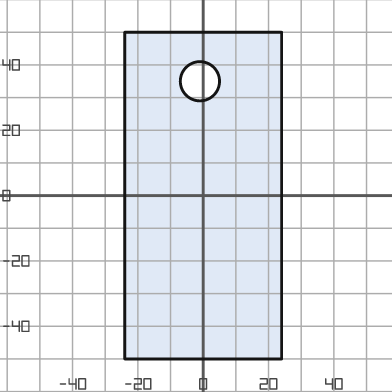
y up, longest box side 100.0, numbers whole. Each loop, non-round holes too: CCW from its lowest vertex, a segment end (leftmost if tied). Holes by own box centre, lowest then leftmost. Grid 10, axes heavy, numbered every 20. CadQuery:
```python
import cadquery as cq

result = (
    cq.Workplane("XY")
    .moveTo(-24.0, -50.0)
    .lineTo(24.0, -50.0)
    .lineTo(24.0, 50.0)
    .lineTo(-24.0, 50.0)
    .close()
    .moveTo(-1.0, 35.0)
    .circle(6.0)
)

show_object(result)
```